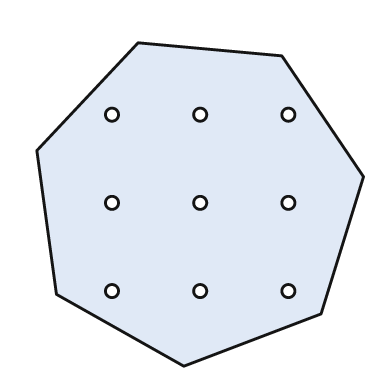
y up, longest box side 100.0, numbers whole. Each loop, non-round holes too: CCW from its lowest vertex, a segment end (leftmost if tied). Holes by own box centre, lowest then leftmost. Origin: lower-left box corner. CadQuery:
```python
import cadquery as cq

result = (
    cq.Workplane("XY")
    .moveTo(45.0, 0.0)
    .lineTo(87.0, 16.0)
    .lineTo(100.0, 58.0)
    .lineTo(75.0, 95.0)
    .lineTo(31.0, 99.0)
    .lineTo(0.0, 66.0)
    .lineTo(6.0, 22.0)
    .close()
    .moveTo(23.0, 23.0)
    .circle(2.0)
    .moveTo(50.0, 23.0)
    .circle(2.0)
    .moveTo(77.0, 23.0)
    .circle(2.0)
    .moveTo(23.0, 50.0)
    .circle(2.0)
    .moveTo(50.0, 50.0)
    .circle(2.0)
    .moveTo(77.0, 50.0)
    .circle(2.0)
    .moveTo(23.0, 77.0)
    .circle(2.0)
    .moveTo(50.0, 77.0)
    .circle(2.0)
    .moveTo(77.0, 77.0)
    .circle(2.0)
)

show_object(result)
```